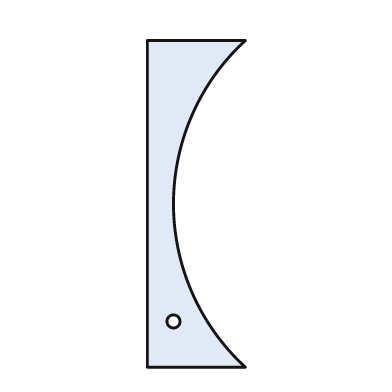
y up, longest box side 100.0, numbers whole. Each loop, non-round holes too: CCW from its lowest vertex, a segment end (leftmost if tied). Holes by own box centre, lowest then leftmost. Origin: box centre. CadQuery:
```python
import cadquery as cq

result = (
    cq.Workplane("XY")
    .moveTo(-15.0, -50.0)
    .lineTo(15.0, -50.0)
    .threePointArc((-7.0, 0.0), (15.0, 50.0))
    .lineTo(-15.0, 50.0)
    .close()
    .moveTo(-7.0, -36.0)
    .circle(2.0)
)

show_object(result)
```